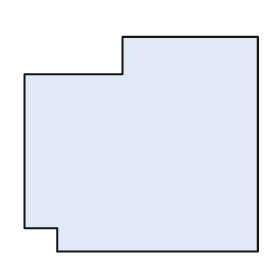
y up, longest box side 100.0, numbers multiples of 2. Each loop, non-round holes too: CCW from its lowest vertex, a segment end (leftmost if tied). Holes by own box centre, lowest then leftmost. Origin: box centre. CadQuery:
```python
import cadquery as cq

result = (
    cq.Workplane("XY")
    .moveTo(-36.0, -46.0)
    .lineTo(50.0, -46.0)
    .lineTo(50.0, 46.0)
    .lineTo(-8.0, 46.0)
    .lineTo(-8.0, 30.0)
    .lineTo(-50.0, 30.0)
    .lineTo(-50.0, -36.0)
    .lineTo(-36.0, -36.0)
    .close()
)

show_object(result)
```